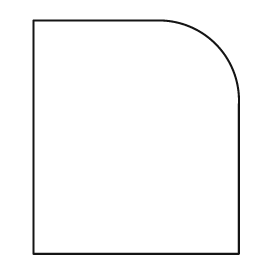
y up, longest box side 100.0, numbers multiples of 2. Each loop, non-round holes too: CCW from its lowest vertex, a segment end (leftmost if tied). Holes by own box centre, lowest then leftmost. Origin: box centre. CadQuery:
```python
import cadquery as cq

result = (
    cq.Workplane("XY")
    .moveTo(-44.0, -50.0)
    .lineTo(44.0, -50.0)
    .lineTo(44.0, 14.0)
    .threePointArc((34.0, 40.0), (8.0, 50.0))
    .lineTo(-44.0, 50.0)
    .close()
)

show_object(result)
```